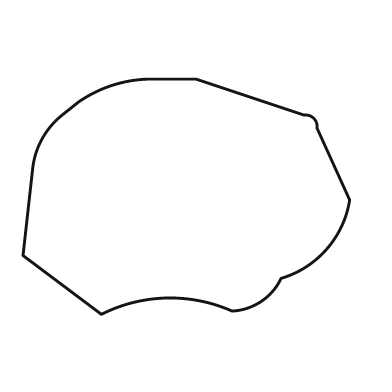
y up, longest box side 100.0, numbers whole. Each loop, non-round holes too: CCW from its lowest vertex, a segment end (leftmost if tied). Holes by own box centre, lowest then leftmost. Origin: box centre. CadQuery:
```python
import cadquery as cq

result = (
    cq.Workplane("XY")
    .moveTo(-26.0, -36.0)
    .threePointArc((-6.0, -31.0), (14.0, -35.0))
    .threePointArc((23.0, -32.0), (29.0, -25.0))
    .threePointArc((43.0, -16.0), (50.0, -1.0))
    .lineTo(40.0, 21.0)
    .threePointArc((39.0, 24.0), (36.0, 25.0))
    .lineTo(3.0, 36.0)
    .lineTo(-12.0, 36.0)
    .threePointArc((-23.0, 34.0), (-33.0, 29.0))
    .lineTo(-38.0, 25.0)
    .threePointArc((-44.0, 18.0), (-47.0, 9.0))
    .lineTo(-50.0, -18.0)
    .close()
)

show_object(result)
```